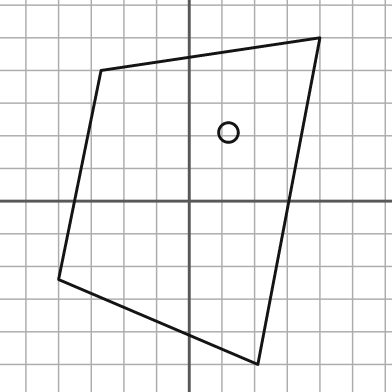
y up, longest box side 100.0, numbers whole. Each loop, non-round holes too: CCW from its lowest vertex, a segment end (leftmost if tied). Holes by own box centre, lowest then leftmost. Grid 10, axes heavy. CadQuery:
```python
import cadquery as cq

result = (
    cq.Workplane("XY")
    .moveTo(21.0, -50.0)
    .lineTo(40.0, 50.0)
    .lineTo(-27.0, 40.0)
    .lineTo(-40.0, -24.0)
    .close()
    .moveTo(12.0, 21.0)
    .circle(3.0)
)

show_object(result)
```